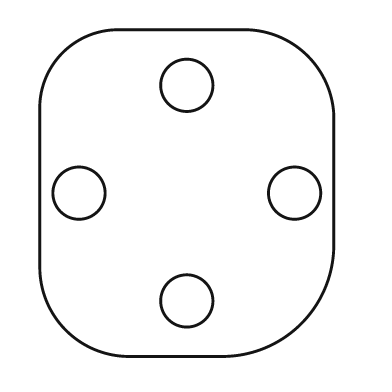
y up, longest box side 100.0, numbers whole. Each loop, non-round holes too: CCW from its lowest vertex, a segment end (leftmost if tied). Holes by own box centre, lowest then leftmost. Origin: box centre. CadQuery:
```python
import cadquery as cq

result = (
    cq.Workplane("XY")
    .moveTo(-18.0, -50.0)
    .lineTo(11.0, -50.0)
    .threePointArc((35.0, -40.0), (45.0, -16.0))
    .lineTo(45.0, 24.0)
    .threePointArc((37.0, 42.0), (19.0, 50.0))
    .lineTo(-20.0, 50.0)
    .threePointArc((-38.0, 43.0), (-45.0, 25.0))
    .lineTo(-45.0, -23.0)
    .threePointArc((-37.0, -42.0), (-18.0, -50.0))
    .close()
    .moveTo(0.0, -33.0)
    .circle(8.0)
    .moveTo(-33.0, 0.0)
    .circle(8.0)
    .moveTo(33.0, 0.0)
    .circle(8.0)
    .moveTo(0.0, 33.0)
    .circle(8.0)
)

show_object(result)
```